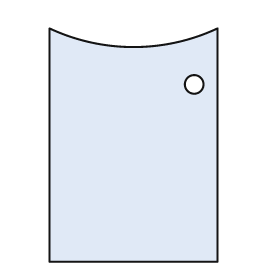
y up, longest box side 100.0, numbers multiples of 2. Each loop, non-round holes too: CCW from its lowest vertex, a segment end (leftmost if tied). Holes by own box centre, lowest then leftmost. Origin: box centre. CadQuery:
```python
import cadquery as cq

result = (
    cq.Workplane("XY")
    .moveTo(-36.0, -50.0)
    .lineTo(36.0, -50.0)
    .lineTo(36.0, 50.0)
    .threePointArc((0.0, 42.0), (-36.0, 50.0))
    .close()
    .moveTo(26.0, 26.0)
    .circle(4.0)
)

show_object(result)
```